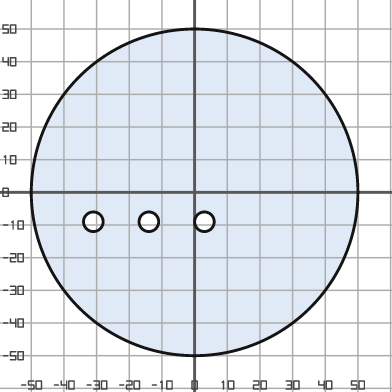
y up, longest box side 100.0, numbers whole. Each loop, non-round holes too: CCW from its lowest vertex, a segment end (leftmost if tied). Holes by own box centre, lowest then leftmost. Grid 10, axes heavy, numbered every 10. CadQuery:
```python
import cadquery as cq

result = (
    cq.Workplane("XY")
    .moveTo(0.0, 0.0)
    .circle(50.0)
    .moveTo(-31.0, -9.0)
    .circle(3.0)
    .moveTo(-14.0, -9.0)
    .circle(3.0)
    .moveTo(3.0, -9.0)
    .circle(3.0)
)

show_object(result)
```